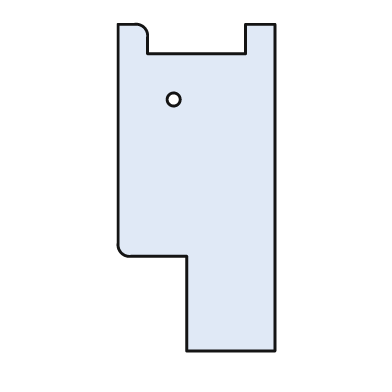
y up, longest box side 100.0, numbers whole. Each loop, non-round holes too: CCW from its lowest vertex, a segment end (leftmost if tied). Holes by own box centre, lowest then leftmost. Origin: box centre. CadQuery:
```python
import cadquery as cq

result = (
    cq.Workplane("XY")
    .moveTo(-3.0, -50.0)
    .lineTo(24.0, -50.0)
    .lineTo(24.0, 50.0)
    .lineTo(15.0, 50.0)
    .lineTo(15.0, 41.0)
    .lineTo(-15.0, 41.0)
    .lineTo(-15.0, 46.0)
    .threePointArc((-16.0, 49.0), (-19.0, 50.0))
    .lineTo(-24.0, 50.0)
    .lineTo(-24.0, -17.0)
    .threePointArc((-23.0, -20.0), (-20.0, -21.0))
    .lineTo(-3.0, -21.0)
    .close()
    .moveTo(-7.0, 27.0)
    .circle(2.0)
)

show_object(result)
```